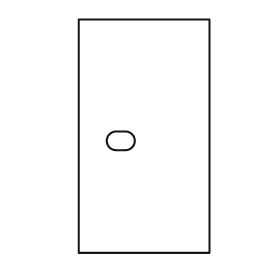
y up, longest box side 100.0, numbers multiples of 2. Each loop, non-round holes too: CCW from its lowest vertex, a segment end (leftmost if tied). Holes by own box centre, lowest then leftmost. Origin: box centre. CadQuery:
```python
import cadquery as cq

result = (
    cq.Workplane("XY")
    .moveTo(-28.0, -50.0)
    .lineTo(28.0, -50.0)
    .lineTo(28.0, 50.0)
    .lineTo(-28.0, 50.0)
    .close()
    .moveTo(-12.0, -6.0)
    .lineTo(-8.0, -6.0)
    .threePointArc((-4.0, -2.0), (-8.0, 2.0))
    .lineTo(-12.0, 2.0)
    .threePointArc((-16.0, -2.0), (-12.0, -6.0))
    .close()
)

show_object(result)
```